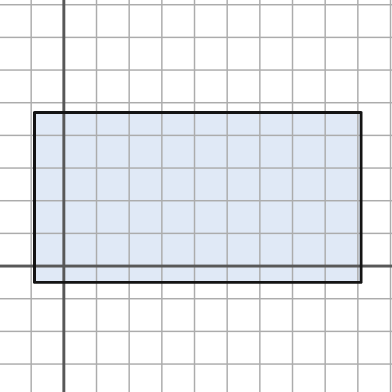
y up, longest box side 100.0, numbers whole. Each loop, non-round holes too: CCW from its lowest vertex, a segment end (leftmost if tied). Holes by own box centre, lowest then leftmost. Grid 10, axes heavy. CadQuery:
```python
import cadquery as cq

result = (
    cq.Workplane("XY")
    .moveTo(-9.0, -5.0)
    .lineTo(91.0, -5.0)
    .lineTo(91.0, 47.0)
    .lineTo(-9.0, 47.0)
    .close()
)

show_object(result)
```